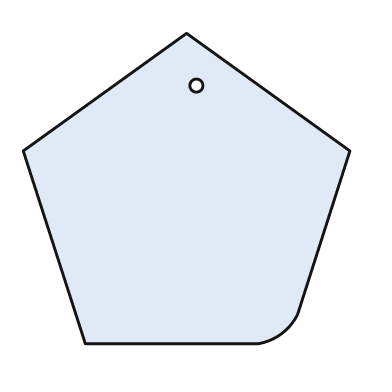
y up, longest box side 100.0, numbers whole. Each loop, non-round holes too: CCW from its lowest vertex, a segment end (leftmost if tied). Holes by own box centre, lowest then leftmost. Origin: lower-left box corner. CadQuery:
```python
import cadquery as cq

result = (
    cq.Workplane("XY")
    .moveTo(19.0, 0.0)
    .lineTo(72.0, 0.0)
    .threePointArc((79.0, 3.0), (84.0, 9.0))
    .lineTo(100.0, 59.0)
    .lineTo(50.0, 95.0)
    .lineTo(0.0, 59.0)
    .close()
    .moveTo(53.0, 79.0)
    .circle(2.0)
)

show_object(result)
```